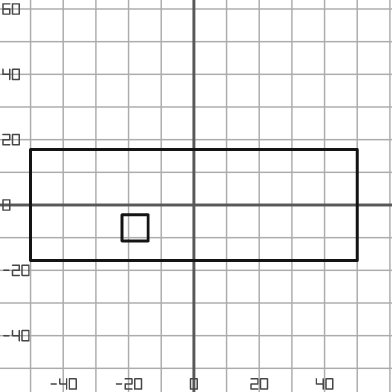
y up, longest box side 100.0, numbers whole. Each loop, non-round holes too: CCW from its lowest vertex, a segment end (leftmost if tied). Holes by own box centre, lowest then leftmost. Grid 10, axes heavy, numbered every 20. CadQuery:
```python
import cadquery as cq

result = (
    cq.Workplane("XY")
    .moveTo(-50.0, -17.0)
    .lineTo(50.0, -17.0)
    .lineTo(50.0, 17.0)
    .lineTo(-50.0, 17.0)
    .close()
    .moveTo(-22.0, -11.0)
    .lineTo(-14.0, -11.0)
    .lineTo(-14.0, -3.0)
    .lineTo(-22.0, -3.0)
    .close()
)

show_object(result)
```